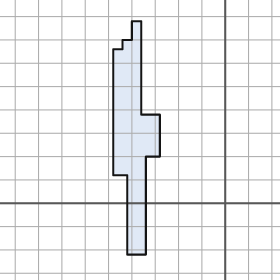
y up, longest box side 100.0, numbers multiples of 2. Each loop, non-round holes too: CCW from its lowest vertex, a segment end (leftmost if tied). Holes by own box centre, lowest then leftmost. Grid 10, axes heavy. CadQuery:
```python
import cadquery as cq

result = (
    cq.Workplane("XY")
    .moveTo(-42.0, -22.0)
    .lineTo(-34.0, -22.0)
    .lineTo(-34.0, 20.0)
    .lineTo(-28.0, 20.0)
    .lineTo(-28.0, 38.0)
    .lineTo(-36.0, 38.0)
    .lineTo(-36.0, 78.0)
    .lineTo(-40.0, 78.0)
    .lineTo(-40.0, 70.0)
    .lineTo(-44.0, 70.0)
    .lineTo(-44.0, 66.0)
    .lineTo(-48.0, 66.0)
    .lineTo(-48.0, 12.0)
    .lineTo(-42.0, 12.0)
    .close()
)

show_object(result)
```